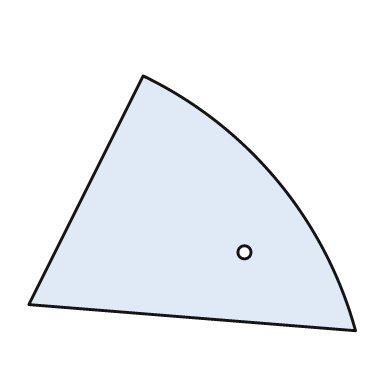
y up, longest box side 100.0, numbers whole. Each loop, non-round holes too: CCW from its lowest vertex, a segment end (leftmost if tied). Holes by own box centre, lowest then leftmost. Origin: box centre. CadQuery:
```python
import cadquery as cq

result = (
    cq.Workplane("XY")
    .moveTo(50.0, -39.0)
    .threePointArc((26.0, 7.0), (-15.0, 39.0))
    .lineTo(-50.0, -31.0)
    .close()
    .moveTo(16.0, -15.0)
    .circle(2.0)
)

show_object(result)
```